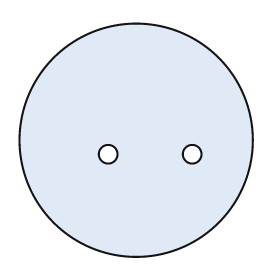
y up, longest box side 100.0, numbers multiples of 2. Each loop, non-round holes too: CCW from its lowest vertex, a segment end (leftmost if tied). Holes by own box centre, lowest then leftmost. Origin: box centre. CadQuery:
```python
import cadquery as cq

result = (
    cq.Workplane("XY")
    .moveTo(0.0, 0.0)
    .circle(50.0)
    .moveTo(-12.0, -6.0)
    .circle(4.0)
    .moveTo(24.0, -6.0)
    .circle(4.0)
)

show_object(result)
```